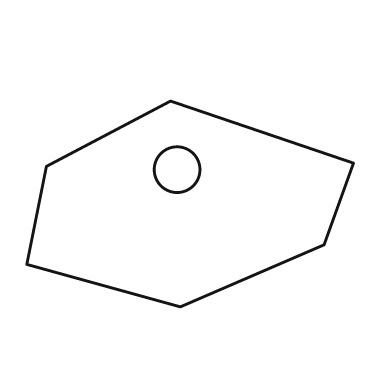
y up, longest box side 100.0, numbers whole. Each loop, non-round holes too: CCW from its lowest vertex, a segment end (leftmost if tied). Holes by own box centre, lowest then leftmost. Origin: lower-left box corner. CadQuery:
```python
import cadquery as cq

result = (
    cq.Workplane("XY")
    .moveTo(47.0, 0.0)
    .lineTo(91.0, 19.0)
    .lineTo(100.0, 44.0)
    .lineTo(44.0, 63.0)
    .lineTo(6.0, 43.0)
    .lineTo(0.0, 13.0)
    .close()
    .moveTo(46.0, 42.0)
    .circle(7.0)
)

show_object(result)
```